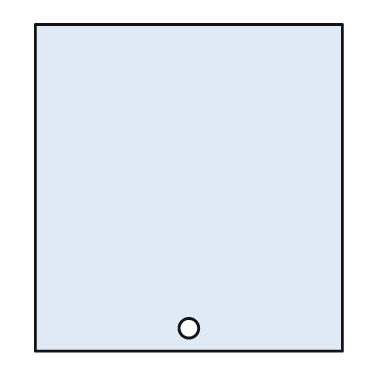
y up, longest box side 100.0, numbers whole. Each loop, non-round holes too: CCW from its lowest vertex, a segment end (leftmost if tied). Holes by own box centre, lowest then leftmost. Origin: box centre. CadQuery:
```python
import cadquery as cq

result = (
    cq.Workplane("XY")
    .moveTo(-47.0, -50.0)
    .lineTo(47.0, -50.0)
    .lineTo(47.0, 50.0)
    .lineTo(-47.0, 50.0)
    .close()
    .moveTo(0.0, -43.0)
    .circle(3.0)
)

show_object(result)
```